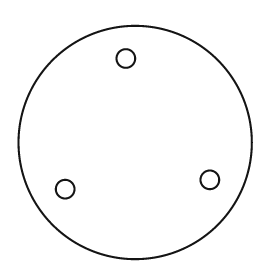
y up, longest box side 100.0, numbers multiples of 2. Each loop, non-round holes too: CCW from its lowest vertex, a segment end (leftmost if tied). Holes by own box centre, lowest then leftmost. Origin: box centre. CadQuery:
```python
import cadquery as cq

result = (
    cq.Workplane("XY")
    .moveTo(0.0, 0.0)
    .circle(50.0)
    .moveTo(-30.0, -20.0)
    .circle(4.0)
    .moveTo(32.0, -16.0)
    .circle(4.0)
    .moveTo(-4.0, 36.0)
    .circle(4.0)
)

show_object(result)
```